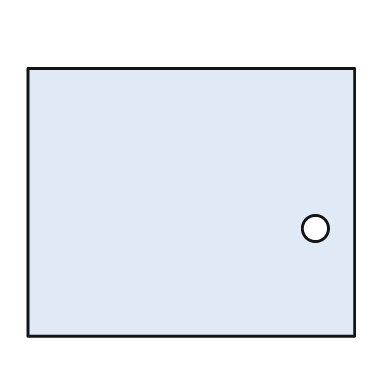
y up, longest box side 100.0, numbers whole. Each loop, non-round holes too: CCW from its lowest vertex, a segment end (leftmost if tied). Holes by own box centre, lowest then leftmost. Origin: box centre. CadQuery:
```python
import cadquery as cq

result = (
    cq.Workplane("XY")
    .moveTo(-50.0, -41.0)
    .lineTo(50.0, -41.0)
    .lineTo(50.0, 41.0)
    .lineTo(-50.0, 41.0)
    .close()
    .moveTo(38.0, -8.0)
    .circle(4.0)
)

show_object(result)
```